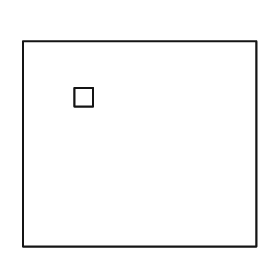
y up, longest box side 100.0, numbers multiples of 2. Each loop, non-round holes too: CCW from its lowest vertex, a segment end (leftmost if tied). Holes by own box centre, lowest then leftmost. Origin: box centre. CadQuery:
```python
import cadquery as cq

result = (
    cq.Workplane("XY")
    .moveTo(-50.0, -44.0)
    .lineTo(50.0, -44.0)
    .lineTo(50.0, 44.0)
    .lineTo(-50.0, 44.0)
    .close()
    .moveTo(-28.0, 16.0)
    .lineTo(-20.0, 16.0)
    .lineTo(-20.0, 24.0)
    .lineTo(-28.0, 24.0)
    .close()
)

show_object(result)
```